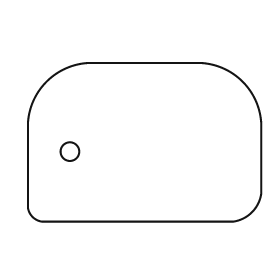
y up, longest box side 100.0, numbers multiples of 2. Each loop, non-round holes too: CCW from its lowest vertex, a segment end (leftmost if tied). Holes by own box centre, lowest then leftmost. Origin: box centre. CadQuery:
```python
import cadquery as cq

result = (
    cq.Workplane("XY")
    .moveTo(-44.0, -34.0)
    .lineTo(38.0, -34.0)
    .threePointArc((46.0, -30.0), (50.0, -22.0))
    .lineTo(50.0, 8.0)
    .threePointArc((42.0, 26.0), (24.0, 34.0))
    .lineTo(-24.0, 34.0)
    .threePointArc((-42.0, 26.0), (-50.0, 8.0))
    .lineTo(-50.0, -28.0)
    .threePointArc((-48.0, -32.0), (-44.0, -34.0))
    .close()
    .moveTo(-32.0, -4.0)
    .circle(4.0)
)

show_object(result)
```